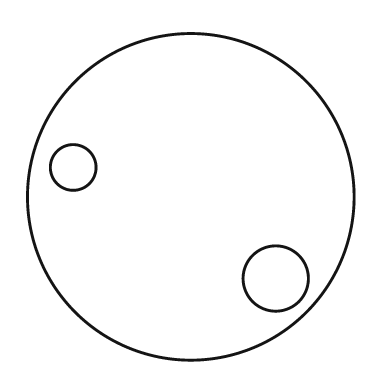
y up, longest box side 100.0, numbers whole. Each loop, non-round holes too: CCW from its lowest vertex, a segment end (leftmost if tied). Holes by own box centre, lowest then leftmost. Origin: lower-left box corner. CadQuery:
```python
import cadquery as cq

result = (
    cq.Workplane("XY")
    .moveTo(50.0, 50.0)
    .circle(50.0)
    .moveTo(76.0, 25.0)
    .circle(10.0)
    .moveTo(14.0, 59.0)
    .circle(7.0)
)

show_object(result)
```